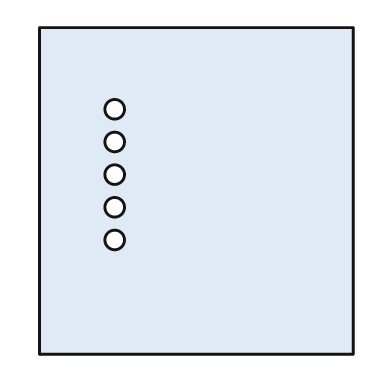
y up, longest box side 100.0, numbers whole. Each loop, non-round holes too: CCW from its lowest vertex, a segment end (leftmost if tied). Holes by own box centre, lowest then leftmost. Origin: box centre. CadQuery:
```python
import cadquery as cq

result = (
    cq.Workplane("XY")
    .moveTo(-48.0, -50.0)
    .lineTo(48.0, -50.0)
    .lineTo(48.0, 50.0)
    .lineTo(-48.0, 50.0)
    .close()
    .moveTo(-25.0, -15.0)
    .circle(3.0)
    .moveTo(-25.0, -5.0)
    .circle(3.0)
    .moveTo(-25.0, 5.0)
    .circle(3.0)
    .moveTo(-25.0, 15.0)
    .circle(3.0)
    .moveTo(-25.0, 25.0)
    .circle(3.0)
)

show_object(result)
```